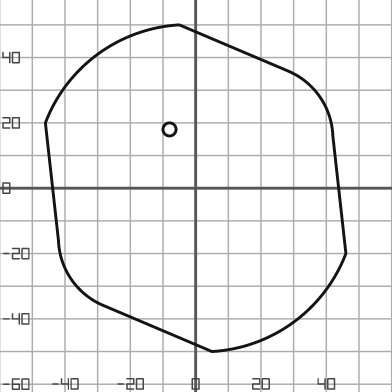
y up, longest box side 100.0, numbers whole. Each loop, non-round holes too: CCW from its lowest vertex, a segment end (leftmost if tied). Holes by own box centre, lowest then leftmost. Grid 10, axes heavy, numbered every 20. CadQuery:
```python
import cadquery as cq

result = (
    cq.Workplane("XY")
    .moveTo(5.0, -50.0)
    .threePointArc((30.0, -41.0), (46.0, -20.0))
    .lineTo(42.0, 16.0)
    .threePointArc((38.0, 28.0), (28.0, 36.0))
    .lineTo(-5.0, 50.0)
    .threePointArc((-30.0, 41.0), (-46.0, 20.0))
    .lineTo(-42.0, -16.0)
    .threePointArc((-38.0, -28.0), (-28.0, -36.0))
    .close()
    .moveTo(-8.0, 18.0)
    .circle(2.0)
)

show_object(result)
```